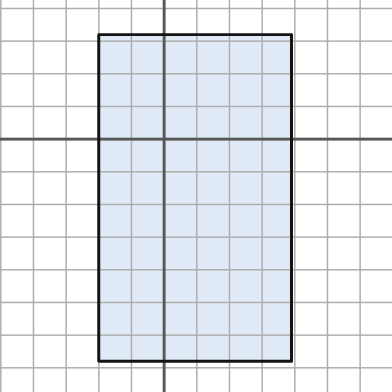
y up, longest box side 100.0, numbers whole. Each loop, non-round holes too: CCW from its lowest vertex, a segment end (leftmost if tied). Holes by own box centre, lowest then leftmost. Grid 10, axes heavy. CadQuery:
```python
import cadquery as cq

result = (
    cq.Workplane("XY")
    .moveTo(-20.0, -68.0)
    .lineTo(39.0, -68.0)
    .lineTo(39.0, 32.0)
    .lineTo(-20.0, 32.0)
    .close()
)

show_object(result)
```